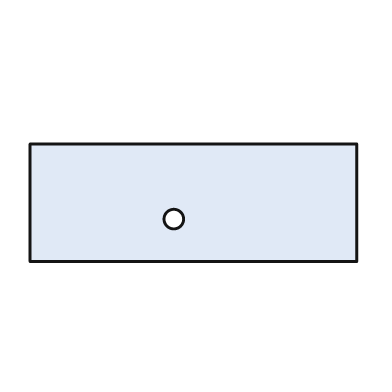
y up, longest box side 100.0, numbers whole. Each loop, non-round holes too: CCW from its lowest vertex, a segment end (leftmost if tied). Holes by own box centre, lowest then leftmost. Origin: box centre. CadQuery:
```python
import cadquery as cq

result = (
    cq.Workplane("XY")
    .moveTo(-50.0, -18.0)
    .lineTo(50.0, -18.0)
    .lineTo(50.0, 18.0)
    .lineTo(-50.0, 18.0)
    .close()
    .moveTo(-6.0, -5.0)
    .circle(3.0)
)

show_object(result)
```